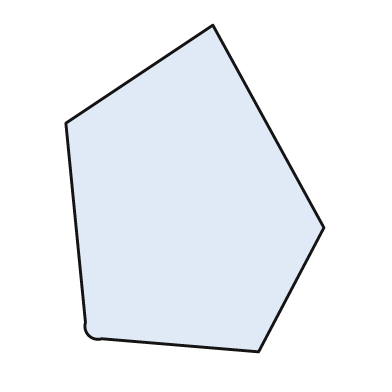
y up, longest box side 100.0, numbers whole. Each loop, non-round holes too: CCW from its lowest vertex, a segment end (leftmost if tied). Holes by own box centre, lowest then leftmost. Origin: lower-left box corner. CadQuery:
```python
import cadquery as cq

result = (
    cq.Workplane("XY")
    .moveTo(59.0, 0.0)
    .lineTo(79.0, 38.0)
    .lineTo(45.0, 100.0)
    .lineTo(0.0, 70.0)
    .lineTo(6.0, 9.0)
    .threePointArc((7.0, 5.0), (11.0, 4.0))
    .close()
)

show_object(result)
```